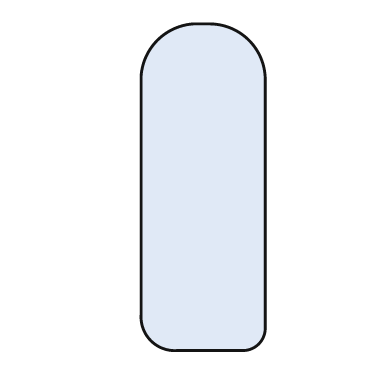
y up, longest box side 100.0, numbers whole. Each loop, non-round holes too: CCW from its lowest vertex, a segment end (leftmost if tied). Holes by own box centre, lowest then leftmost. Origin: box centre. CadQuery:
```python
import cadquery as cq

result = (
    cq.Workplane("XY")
    .moveTo(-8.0, -50.0)
    .lineTo(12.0, -50.0)
    .threePointArc((17.0, -48.0), (19.0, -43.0))
    .lineTo(19.0, 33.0)
    .threePointArc((14.0, 45.0), (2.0, 50.0))
    .lineTo(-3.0, 50.0)
    .threePointArc((-14.0, 45.0), (-19.0, 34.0))
    .lineTo(-19.0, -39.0)
    .threePointArc((-16.0, -47.0), (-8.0, -50.0))
    .close()
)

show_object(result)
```